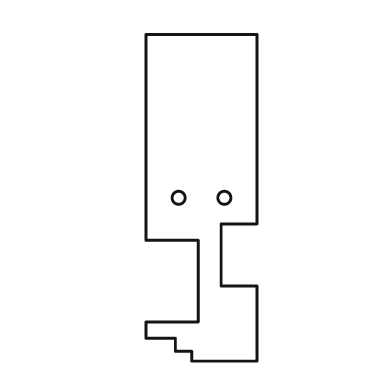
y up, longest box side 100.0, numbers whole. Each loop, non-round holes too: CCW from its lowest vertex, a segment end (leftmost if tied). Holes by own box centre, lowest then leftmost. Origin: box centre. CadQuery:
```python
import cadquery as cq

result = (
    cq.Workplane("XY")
    .moveTo(-3.0, -50.0)
    .lineTo(17.0, -50.0)
    .lineTo(17.0, -27.0)
    .lineTo(6.0, -27.0)
    .lineTo(6.0, -8.0)
    .lineTo(17.0, -8.0)
    .lineTo(17.0, 50.0)
    .lineTo(-17.0, 50.0)
    .lineTo(-17.0, -13.0)
    .lineTo(-1.0, -13.0)
    .lineTo(-1.0, -38.0)
    .lineTo(-17.0, -38.0)
    .lineTo(-17.0, -43.0)
    .lineTo(-8.0, -43.0)
    .lineTo(-8.0, -47.0)
    .lineTo(-3.0, -47.0)
    .close()
    .moveTo(-7.0, 0.0)
    .circle(2.0)
    .moveTo(7.0, 0.0)
    .circle(2.0)
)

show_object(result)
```